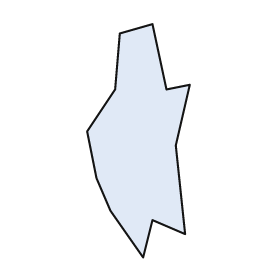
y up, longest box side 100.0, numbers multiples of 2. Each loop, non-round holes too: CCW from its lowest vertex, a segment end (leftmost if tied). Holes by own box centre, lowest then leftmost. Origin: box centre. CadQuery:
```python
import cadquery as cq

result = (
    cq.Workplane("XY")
    .moveTo(2.0, -50.0)
    .lineTo(6.0, -34.0)
    .lineTo(20.0, -40.0)
    .lineTo(16.0, -2.0)
    .lineTo(22.0, 24.0)
    .lineTo(12.0, 22.0)
    .lineTo(6.0, 50.0)
    .lineTo(-8.0, 46.0)
    .lineTo(-10.0, 22.0)
    .lineTo(-22.0, 4.0)
    .lineTo(-18.0, -16.0)
    .lineTo(-12.0, -30.0)
    .close()
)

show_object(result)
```